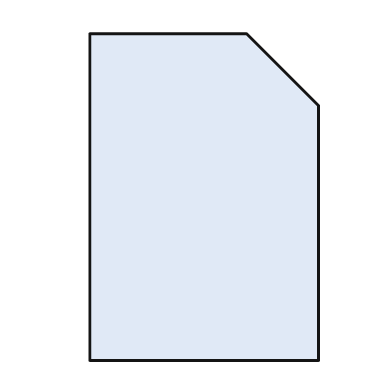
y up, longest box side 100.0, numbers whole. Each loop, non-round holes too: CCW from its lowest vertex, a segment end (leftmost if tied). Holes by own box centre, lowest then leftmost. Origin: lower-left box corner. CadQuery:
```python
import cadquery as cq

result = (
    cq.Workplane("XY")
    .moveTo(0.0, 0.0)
    .lineTo(70.0, 0.0)
    .lineTo(70.0, 78.0)
    .lineTo(48.0, 100.0)
    .lineTo(0.0, 100.0)
    .close()
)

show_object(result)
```